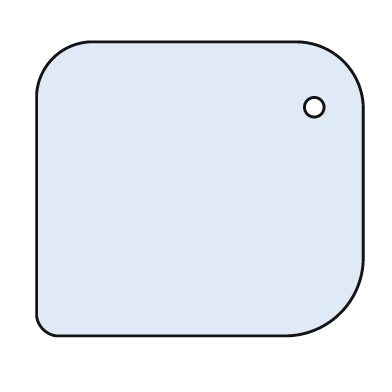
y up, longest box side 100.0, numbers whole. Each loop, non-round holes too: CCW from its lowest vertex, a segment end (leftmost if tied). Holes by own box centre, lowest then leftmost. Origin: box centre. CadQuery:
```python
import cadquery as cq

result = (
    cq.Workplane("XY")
    .moveTo(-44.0, -45.0)
    .lineTo(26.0, -45.0)
    .threePointArc((43.0, -38.0), (50.0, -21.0))
    .lineTo(50.0, 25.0)
    .threePointArc((44.0, 39.0), (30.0, 45.0))
    .lineTo(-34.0, 45.0)
    .threePointArc((-45.0, 40.0), (-50.0, 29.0))
    .lineTo(-50.0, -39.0)
    .threePointArc((-48.0, -43.0), (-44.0, -45.0))
    .close()
    .moveTo(35.0, 25.0)
    .circle(3.0)
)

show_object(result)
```